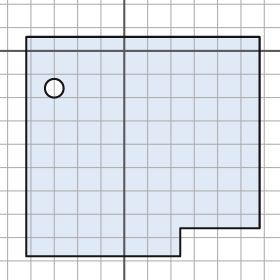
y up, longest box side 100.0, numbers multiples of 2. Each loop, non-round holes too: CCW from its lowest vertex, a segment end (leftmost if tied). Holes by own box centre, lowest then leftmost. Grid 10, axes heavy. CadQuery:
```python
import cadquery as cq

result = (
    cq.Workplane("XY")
    .moveTo(-42.0, -88.0)
    .lineTo(24.0, -88.0)
    .lineTo(24.0, -76.0)
    .lineTo(58.0, -76.0)
    .lineTo(58.0, 6.0)
    .lineTo(-42.0, 6.0)
    .close()
    .moveTo(-30.0, -16.0)
    .circle(4.0)
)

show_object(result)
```